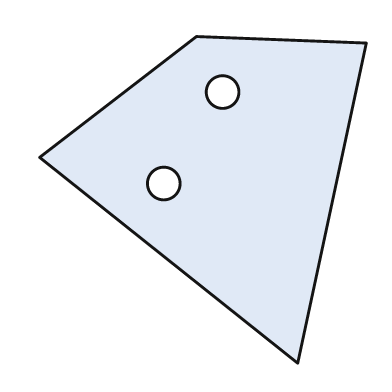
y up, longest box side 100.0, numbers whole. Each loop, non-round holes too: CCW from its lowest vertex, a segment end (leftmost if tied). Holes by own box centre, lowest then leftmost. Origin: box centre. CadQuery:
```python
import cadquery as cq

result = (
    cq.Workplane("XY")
    .moveTo(29.0, -50.0)
    .lineTo(50.0, 48.0)
    .lineTo(-2.0, 50.0)
    .lineTo(-50.0, 13.0)
    .close()
    .moveTo(-12.0, 5.0)
    .circle(5.0)
    .moveTo(6.0, 33.0)
    .circle(5.0)
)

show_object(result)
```